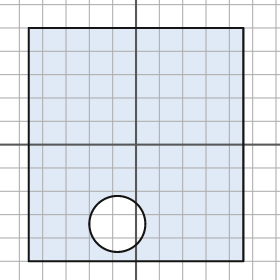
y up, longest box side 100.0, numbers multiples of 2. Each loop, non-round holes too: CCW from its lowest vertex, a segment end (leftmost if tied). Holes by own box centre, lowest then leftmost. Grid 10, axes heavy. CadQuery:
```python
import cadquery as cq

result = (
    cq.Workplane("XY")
    .moveTo(-46.0, -50.0)
    .lineTo(46.0, -50.0)
    .lineTo(46.0, 50.0)
    .lineTo(-46.0, 50.0)
    .close()
    .moveTo(-8.0, -34.0)
    .circle(12.0)
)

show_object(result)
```